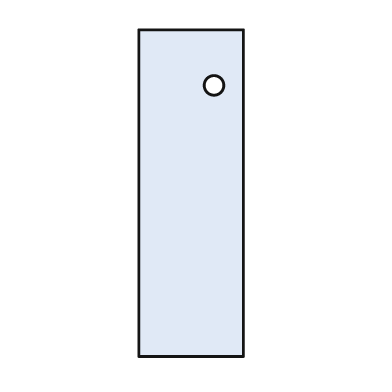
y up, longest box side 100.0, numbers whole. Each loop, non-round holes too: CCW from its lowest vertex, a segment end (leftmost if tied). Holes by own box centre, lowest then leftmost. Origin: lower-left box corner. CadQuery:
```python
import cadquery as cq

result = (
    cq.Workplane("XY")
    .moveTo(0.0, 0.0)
    .lineTo(32.0, 0.0)
    .lineTo(32.0, 100.0)
    .lineTo(0.0, 100.0)
    .close()
    .moveTo(23.0, 83.0)
    .circle(3.0)
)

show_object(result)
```